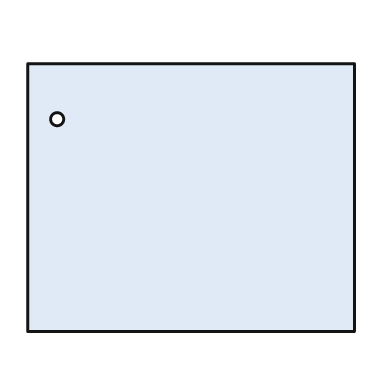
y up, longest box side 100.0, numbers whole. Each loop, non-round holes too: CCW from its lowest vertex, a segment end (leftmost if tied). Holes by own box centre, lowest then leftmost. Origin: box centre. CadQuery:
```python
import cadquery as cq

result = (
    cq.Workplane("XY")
    .moveTo(-50.0, -41.0)
    .lineTo(50.0, -41.0)
    .lineTo(50.0, 41.0)
    .lineTo(-50.0, 41.0)
    .close()
    .moveTo(-41.0, 24.0)
    .circle(2.0)
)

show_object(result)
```